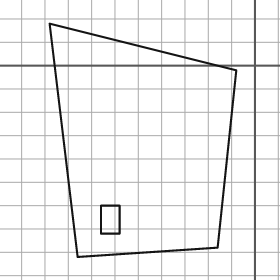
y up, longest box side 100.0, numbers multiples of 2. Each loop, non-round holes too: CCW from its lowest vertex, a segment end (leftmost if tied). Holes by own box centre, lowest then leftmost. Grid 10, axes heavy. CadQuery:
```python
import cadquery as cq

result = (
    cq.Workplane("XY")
    .moveTo(-76.0, -82.0)
    .lineTo(-16.0, -78.0)
    .lineTo(-8.0, -2.0)
    .lineTo(-88.0, 18.0)
    .close()
    .moveTo(-66.0, -72.0)
    .lineTo(-58.0, -72.0)
    .lineTo(-58.0, -60.0)
    .lineTo(-66.0, -60.0)
    .close()
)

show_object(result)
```